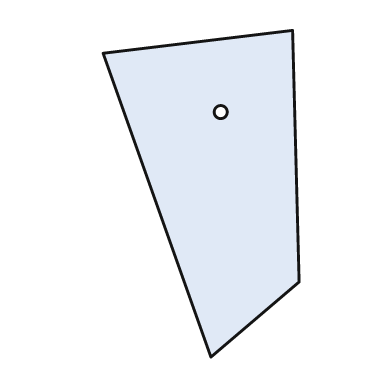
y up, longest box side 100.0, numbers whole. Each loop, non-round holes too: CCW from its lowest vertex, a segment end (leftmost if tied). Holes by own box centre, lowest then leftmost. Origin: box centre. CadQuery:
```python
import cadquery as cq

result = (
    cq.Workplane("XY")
    .moveTo(3.0, -50.0)
    .lineTo(30.0, -27.0)
    .lineTo(28.0, 50.0)
    .lineTo(-30.0, 43.0)
    .close()
    .moveTo(6.0, 25.0)
    .circle(2.0)
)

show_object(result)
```